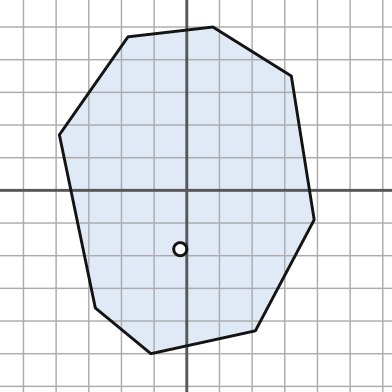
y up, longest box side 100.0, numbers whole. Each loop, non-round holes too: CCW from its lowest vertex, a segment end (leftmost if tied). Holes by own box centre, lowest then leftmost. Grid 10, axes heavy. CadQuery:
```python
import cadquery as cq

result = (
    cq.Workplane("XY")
    .moveTo(-11.0, -50.0)
    .lineTo(21.0, -43.0)
    .lineTo(39.0, -9.0)
    .lineTo(32.0, 35.0)
    .lineTo(8.0, 50.0)
    .lineTo(-18.0, 47.0)
    .lineTo(-39.0, 17.0)
    .lineTo(-28.0, -36.0)
    .close()
    .moveTo(-2.0, -18.0)
    .circle(2.0)
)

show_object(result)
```